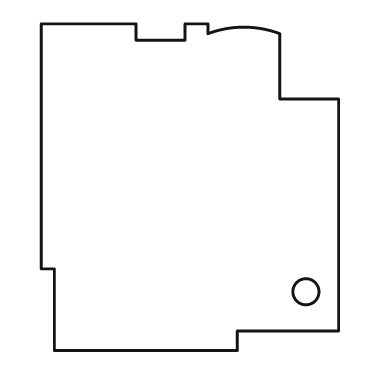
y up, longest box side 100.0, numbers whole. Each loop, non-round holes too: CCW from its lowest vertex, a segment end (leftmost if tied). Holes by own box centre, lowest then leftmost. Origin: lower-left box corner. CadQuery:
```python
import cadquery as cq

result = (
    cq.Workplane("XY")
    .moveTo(4.0, 0.0)
    .lineTo(60.0, 0.0)
    .lineTo(60.0, 6.0)
    .lineTo(91.0, 6.0)
    .lineTo(91.0, 77.0)
    .lineTo(73.0, 77.0)
    .lineTo(73.0, 97.0)
    .threePointArc((62.0, 99.0), (51.0, 97.0))
    .lineTo(51.0, 100.0)
    .lineTo(44.0, 100.0)
    .lineTo(44.0, 95.0)
    .lineTo(29.0, 95.0)
    .lineTo(29.0, 100.0)
    .lineTo(0.0, 100.0)
    .lineTo(0.0, 25.0)
    .lineTo(4.0, 25.0)
    .close()
    .moveTo(81.0, 18.0)
    .circle(4.0)
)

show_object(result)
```